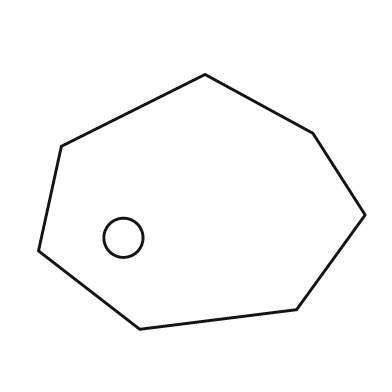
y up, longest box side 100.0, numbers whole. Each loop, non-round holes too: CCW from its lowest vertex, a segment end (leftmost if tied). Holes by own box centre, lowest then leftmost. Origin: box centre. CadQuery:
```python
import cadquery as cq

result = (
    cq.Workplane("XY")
    .moveTo(-19.0, -39.0)
    .lineTo(29.0, -33.0)
    .lineTo(50.0, -4.0)
    .lineTo(34.0, 21.0)
    .lineTo(1.0, 39.0)
    .lineTo(-43.0, 17.0)
    .lineTo(-50.0, -15.0)
    .close()
    .moveTo(-24.0, -11.0)
    .circle(6.0)
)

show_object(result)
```